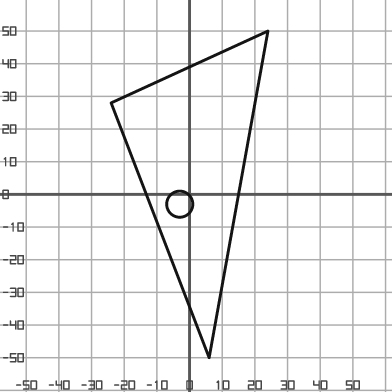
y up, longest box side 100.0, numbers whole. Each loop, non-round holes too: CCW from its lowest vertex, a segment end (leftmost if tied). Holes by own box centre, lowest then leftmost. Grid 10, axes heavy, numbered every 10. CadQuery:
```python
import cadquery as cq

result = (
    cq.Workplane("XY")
    .moveTo(6.0, -50.0)
    .lineTo(24.0, 50.0)
    .lineTo(-24.0, 28.0)
    .close()
    .moveTo(-3.0, -3.0)
    .circle(4.0)
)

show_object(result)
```